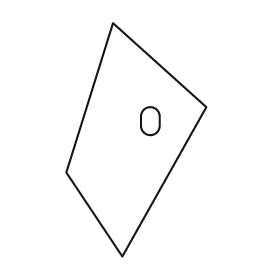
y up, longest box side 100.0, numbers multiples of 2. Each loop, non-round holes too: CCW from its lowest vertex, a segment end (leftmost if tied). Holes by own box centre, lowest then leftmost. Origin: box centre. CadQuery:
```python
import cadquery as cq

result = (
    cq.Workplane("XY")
    .moveTo(-6.0, -50.0)
    .lineTo(30.0, 14.0)
    .lineTo(-10.0, 50.0)
    .lineTo(-30.0, -14.0)
    .close()
    .moveTo(2.0, 6.0)
    .threePointArc((6.0, 2.0), (10.0, 6.0))
    .lineTo(10.0, 10.0)
    .threePointArc((6.0, 14.0), (2.0, 10.0))
    .close()
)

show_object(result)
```